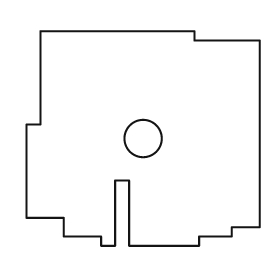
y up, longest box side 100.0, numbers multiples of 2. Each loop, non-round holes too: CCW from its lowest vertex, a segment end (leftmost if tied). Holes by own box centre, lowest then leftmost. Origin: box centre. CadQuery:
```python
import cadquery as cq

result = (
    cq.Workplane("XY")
    .moveTo(-18.0, -46.0)
    .lineTo(-12.0, -46.0)
    .lineTo(-12.0, -18.0)
    .lineTo(-6.0, -18.0)
    .lineTo(-6.0, -46.0)
    .lineTo(24.0, -46.0)
    .lineTo(24.0, -42.0)
    .lineTo(38.0, -42.0)
    .lineTo(38.0, -38.0)
    .lineTo(50.0, -38.0)
    .lineTo(50.0, 42.0)
    .lineTo(22.0, 42.0)
    .lineTo(22.0, 46.0)
    .lineTo(-44.0, 46.0)
    .lineTo(-44.0, 6.0)
    .lineTo(-50.0, 6.0)
    .lineTo(-50.0, -34.0)
    .lineTo(-34.0, -34.0)
    .lineTo(-34.0, -42.0)
    .lineTo(-18.0, -42.0)
    .close()
    .moveTo(0.0, 0.0)
    .circle(8.0)
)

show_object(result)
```